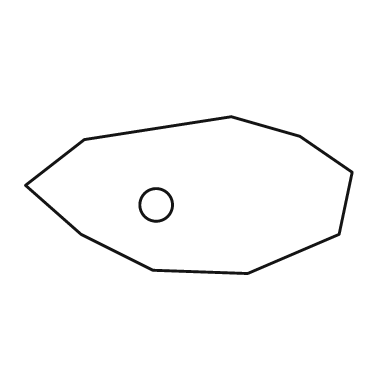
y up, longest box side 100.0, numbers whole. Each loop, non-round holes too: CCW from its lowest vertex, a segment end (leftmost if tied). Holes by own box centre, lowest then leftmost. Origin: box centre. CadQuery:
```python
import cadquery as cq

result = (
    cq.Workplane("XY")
    .moveTo(18.0, -24.0)
    .lineTo(46.0, -12.0)
    .lineTo(50.0, 7.0)
    .lineTo(34.0, 18.0)
    .lineTo(13.0, 24.0)
    .lineTo(-32.0, 17.0)
    .lineTo(-50.0, 3.0)
    .lineTo(-33.0, -12.0)
    .lineTo(-11.0, -23.0)
    .close()
    .moveTo(-10.0, -3.0)
    .circle(5.0)
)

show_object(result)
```